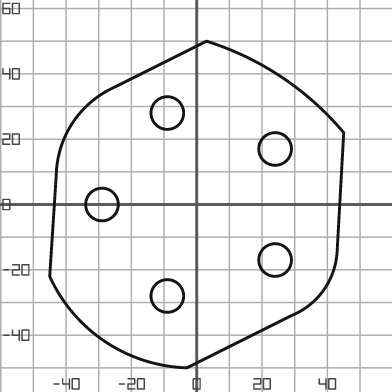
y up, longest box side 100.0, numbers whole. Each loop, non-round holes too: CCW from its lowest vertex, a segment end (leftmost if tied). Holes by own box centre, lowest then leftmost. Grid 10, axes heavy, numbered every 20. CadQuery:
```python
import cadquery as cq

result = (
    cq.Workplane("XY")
    .moveTo(-3.0, -50.0)
    .lineTo(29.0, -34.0)
    .threePointArc((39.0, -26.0), (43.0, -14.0))
    .lineTo(45.0, 22.0)
    .threePointArc((26.0, 39.0), (3.0, 50.0))
    .lineTo(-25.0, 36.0)
    .threePointArc((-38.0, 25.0), (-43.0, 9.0))
    .lineTo(-45.0, -22.0)
    .threePointArc((-28.0, -42.0), (-3.0, -50.0))
    .close()
    .moveTo(-9.0, -28.0)
    .circle(5.0)
    .moveTo(24.0, -17.0)
    .circle(5.0)
    .moveTo(-29.0, 0.0)
    .circle(5.0)
    .moveTo(24.0, 17.0)
    .circle(5.0)
    .moveTo(-9.0, 28.0)
    .circle(5.0)
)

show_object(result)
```